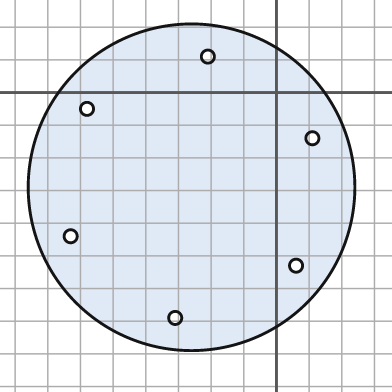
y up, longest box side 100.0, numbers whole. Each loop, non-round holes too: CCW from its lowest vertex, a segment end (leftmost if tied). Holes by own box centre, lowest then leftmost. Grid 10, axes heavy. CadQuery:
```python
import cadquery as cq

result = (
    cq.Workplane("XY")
    .moveTo(-26.0, -29.0)
    .circle(50.0)
    .moveTo(-31.0, -69.0)
    .circle(2.0)
    .moveTo(6.0, -53.0)
    .circle(2.0)
    .moveTo(-63.0, -44.0)
    .circle(2.0)
    .moveTo(11.0, -14.0)
    .circle(2.0)
    .moveTo(-58.0, -5.0)
    .circle(2.0)
    .moveTo(-21.0, 11.0)
    .circle(2.0)
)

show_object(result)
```